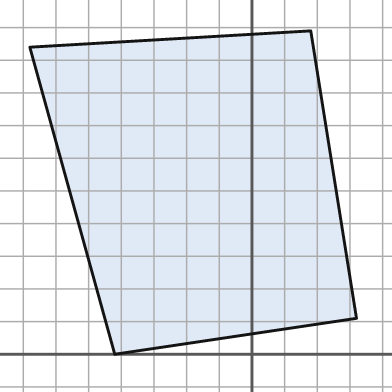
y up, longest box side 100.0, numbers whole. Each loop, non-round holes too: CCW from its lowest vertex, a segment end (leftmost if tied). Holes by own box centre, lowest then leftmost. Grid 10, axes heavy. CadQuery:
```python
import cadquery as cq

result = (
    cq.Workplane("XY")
    .moveTo(-42.0, 0.0)
    .lineTo(32.0, 11.0)
    .lineTo(18.0, 99.0)
    .lineTo(-68.0, 94.0)
    .close()
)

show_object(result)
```